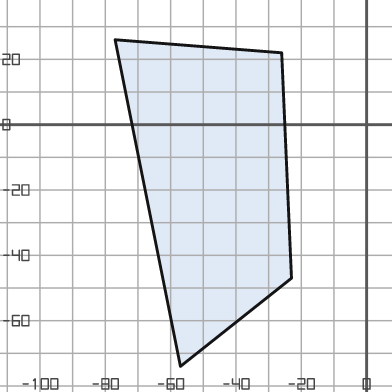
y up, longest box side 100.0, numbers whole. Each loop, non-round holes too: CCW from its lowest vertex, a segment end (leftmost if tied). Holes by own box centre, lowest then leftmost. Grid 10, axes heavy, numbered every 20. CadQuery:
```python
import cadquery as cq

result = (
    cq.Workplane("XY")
    .moveTo(-57.0, -74.0)
    .lineTo(-23.0, -47.0)
    .lineTo(-26.0, 22.0)
    .lineTo(-77.0, 26.0)
    .close()
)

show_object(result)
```